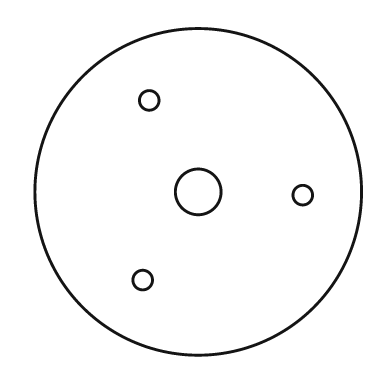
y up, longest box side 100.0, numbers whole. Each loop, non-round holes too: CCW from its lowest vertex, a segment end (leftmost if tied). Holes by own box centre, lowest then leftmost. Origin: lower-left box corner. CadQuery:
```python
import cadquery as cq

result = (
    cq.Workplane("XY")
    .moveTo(50.0, 50.0)
    .circle(50.0)
    .moveTo(33.0, 23.0)
    .circle(3.0)
    .moveTo(82.0, 49.0)
    .circle(3.0)
    .moveTo(50.0, 50.0)
    .circle(7.0)
    .moveTo(35.0, 78.0)
    .circle(3.0)
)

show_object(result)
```